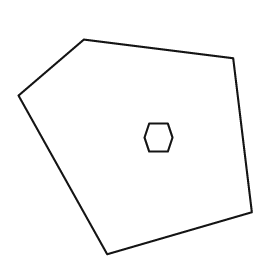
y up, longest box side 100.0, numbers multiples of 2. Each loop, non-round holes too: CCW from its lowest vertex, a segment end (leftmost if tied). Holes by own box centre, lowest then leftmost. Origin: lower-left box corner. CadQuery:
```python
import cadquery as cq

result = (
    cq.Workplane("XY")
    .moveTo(38.0, 0.0)
    .lineTo(100.0, 18.0)
    .lineTo(92.0, 84.0)
    .lineTo(28.0, 92.0)
    .lineTo(0.0, 68.0)
    .close()
    .moveTo(56.0, 44.0)
    .lineTo(64.0, 44.0)
    .lineTo(66.0, 50.0)
    .lineTo(64.0, 56.0)
    .lineTo(56.0, 56.0)
    .lineTo(54.0, 50.0)
    .close()
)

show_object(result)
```